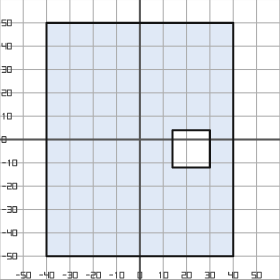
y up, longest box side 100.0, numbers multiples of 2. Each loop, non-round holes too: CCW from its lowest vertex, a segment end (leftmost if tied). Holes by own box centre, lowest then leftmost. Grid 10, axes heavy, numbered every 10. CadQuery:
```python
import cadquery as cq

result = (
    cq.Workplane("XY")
    .moveTo(-40.0, -50.0)
    .lineTo(40.0, -50.0)
    .lineTo(40.0, 50.0)
    .lineTo(-40.0, 50.0)
    .close()
    .moveTo(14.0, -12.0)
    .lineTo(30.0, -12.0)
    .lineTo(30.0, 4.0)
    .lineTo(14.0, 4.0)
    .close()
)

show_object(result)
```